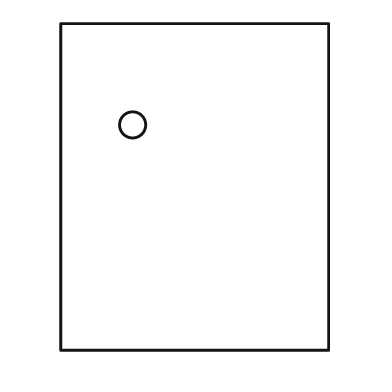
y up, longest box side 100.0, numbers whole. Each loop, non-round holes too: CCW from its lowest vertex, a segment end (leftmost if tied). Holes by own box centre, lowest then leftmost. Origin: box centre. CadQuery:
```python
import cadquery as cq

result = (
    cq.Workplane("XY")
    .moveTo(-41.0, -50.0)
    .lineTo(41.0, -50.0)
    .lineTo(41.0, 50.0)
    .lineTo(-41.0, 50.0)
    .close()
    .moveTo(-19.0, 19.0)
    .circle(4.0)
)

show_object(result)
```